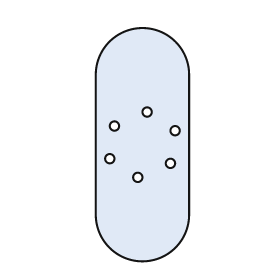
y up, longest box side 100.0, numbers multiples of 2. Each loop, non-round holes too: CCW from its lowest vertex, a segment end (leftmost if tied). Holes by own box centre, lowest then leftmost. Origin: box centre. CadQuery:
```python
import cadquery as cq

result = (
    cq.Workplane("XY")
    .moveTo(-20.0, -30.0)
    .threePointArc((0.0, -50.0), (20.0, -30.0))
    .lineTo(20.0, 30.0)
    .threePointArc((0.0, 50.0), (-20.0, 30.0))
    .close()
    .moveTo(-2.0, -14.0)
    .circle(2.0)
    .moveTo(12.0, -8.0)
    .circle(2.0)
    .moveTo(-14.0, -6.0)
    .circle(2.0)
    .moveTo(14.0, 6.0)
    .circle(2.0)
    .moveTo(-12.0, 8.0)
    .circle(2.0)
    .moveTo(2.0, 14.0)
    .circle(2.0)
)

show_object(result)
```